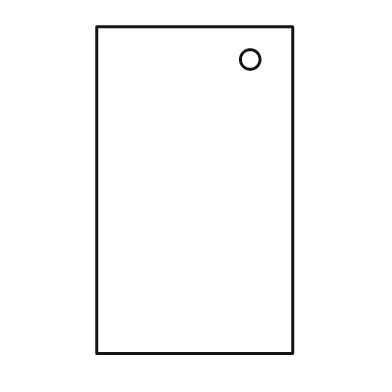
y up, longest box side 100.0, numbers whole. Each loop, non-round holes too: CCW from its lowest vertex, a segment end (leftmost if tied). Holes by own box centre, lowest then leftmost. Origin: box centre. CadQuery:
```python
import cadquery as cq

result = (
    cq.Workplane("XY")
    .moveTo(-30.0, -50.0)
    .lineTo(30.0, -50.0)
    .lineTo(30.0, 50.0)
    .lineTo(-30.0, 50.0)
    .close()
    .moveTo(17.0, 40.0)
    .circle(3.0)
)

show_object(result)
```